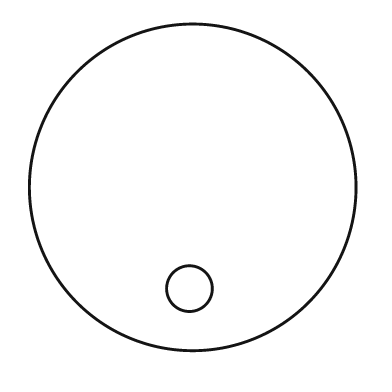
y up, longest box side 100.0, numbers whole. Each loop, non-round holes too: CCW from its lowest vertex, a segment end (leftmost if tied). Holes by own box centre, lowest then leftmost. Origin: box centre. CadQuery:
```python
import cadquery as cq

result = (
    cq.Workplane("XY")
    .moveTo(0.0, 0.0)
    .circle(50.0)
    .moveTo(-1.0, -31.0)
    .circle(7.0)
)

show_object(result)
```